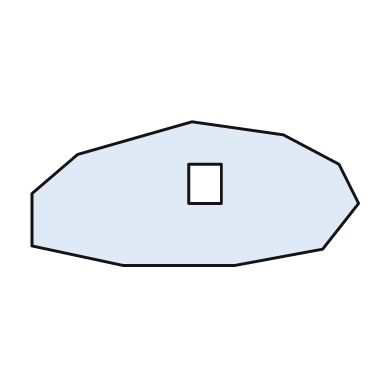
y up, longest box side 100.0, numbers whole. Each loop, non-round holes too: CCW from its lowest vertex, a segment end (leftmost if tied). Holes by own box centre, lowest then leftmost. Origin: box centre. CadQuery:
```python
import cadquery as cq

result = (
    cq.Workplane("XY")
    .moveTo(-22.0, -22.0)
    .lineTo(12.0, -22.0)
    .lineTo(39.0, -17.0)
    .lineTo(50.0, -3.0)
    .lineTo(44.0, 9.0)
    .lineTo(27.0, 18.0)
    .lineTo(-1.0, 22.0)
    .lineTo(-36.0, 12.0)
    .lineTo(-50.0, 0.0)
    .lineTo(-50.0, -16.0)
    .close()
    .moveTo(-2.0, -3.0)
    .lineTo(8.0, -3.0)
    .lineTo(8.0, 9.0)
    .lineTo(-2.0, 9.0)
    .close()
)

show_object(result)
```